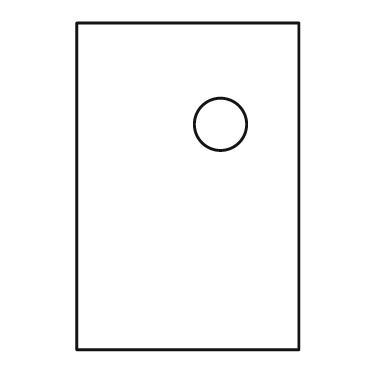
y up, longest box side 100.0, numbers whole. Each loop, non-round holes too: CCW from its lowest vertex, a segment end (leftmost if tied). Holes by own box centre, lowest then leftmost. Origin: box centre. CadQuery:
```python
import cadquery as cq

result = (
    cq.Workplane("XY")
    .moveTo(-34.0, -50.0)
    .lineTo(34.0, -50.0)
    .lineTo(34.0, 50.0)
    .lineTo(-34.0, 50.0)
    .close()
    .moveTo(10.0, 19.0)
    .circle(8.0)
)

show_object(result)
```